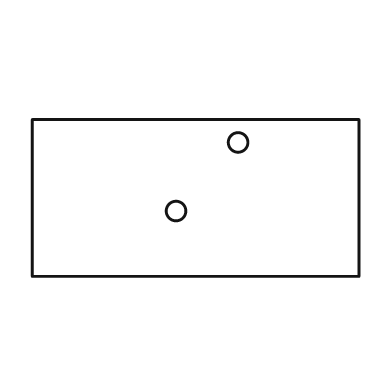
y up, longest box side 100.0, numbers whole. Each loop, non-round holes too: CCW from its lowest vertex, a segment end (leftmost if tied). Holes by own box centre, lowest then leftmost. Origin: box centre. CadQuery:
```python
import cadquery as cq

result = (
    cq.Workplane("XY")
    .moveTo(-50.0, -24.0)
    .lineTo(50.0, -24.0)
    .lineTo(50.0, 24.0)
    .lineTo(-50.0, 24.0)
    .close()
    .moveTo(-6.0, -4.0)
    .circle(3.0)
    .moveTo(13.0, 17.0)
    .circle(3.0)
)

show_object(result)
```